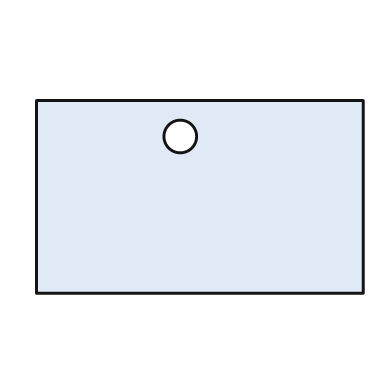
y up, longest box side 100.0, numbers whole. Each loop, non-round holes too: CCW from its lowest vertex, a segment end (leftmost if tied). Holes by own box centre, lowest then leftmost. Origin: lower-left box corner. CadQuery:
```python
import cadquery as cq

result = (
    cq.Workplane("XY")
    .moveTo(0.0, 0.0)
    .lineTo(100.0, 0.0)
    .lineTo(100.0, 59.0)
    .lineTo(0.0, 59.0)
    .close()
    .moveTo(44.0, 48.0)
    .circle(5.0)
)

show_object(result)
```